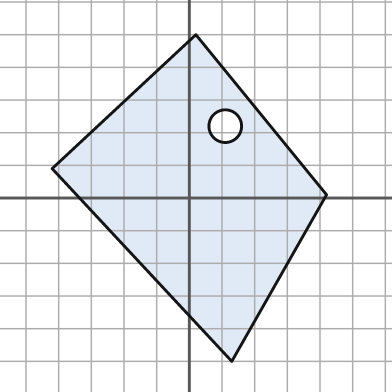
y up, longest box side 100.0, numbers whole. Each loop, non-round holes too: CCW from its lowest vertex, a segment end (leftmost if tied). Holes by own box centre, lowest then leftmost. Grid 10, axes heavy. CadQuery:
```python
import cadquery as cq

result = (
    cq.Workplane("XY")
    .moveTo(13.0, -50.0)
    .lineTo(42.0, 1.0)
    .lineTo(2.0, 50.0)
    .lineTo(-42.0, 9.0)
    .close()
    .moveTo(11.0, 22.0)
    .circle(5.0)
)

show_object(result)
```